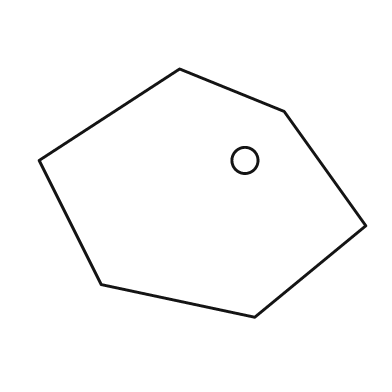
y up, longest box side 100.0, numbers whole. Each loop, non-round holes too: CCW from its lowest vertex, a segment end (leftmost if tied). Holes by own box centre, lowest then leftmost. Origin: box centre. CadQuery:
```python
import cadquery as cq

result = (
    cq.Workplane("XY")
    .moveTo(16.0, -38.0)
    .lineTo(50.0, -10.0)
    .lineTo(25.0, 25.0)
    .lineTo(-7.0, 38.0)
    .lineTo(-50.0, 10.0)
    .lineTo(-31.0, -28.0)
    .close()
    .moveTo(13.0, 10.0)
    .circle(4.0)
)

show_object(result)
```